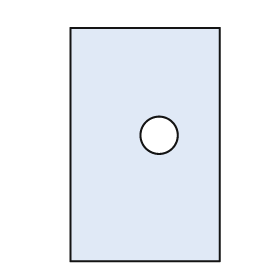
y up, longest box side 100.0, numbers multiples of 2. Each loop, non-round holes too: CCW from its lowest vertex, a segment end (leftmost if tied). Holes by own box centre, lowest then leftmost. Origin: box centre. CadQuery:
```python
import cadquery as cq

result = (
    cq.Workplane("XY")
    .moveTo(-32.0, -50.0)
    .lineTo(32.0, -50.0)
    .lineTo(32.0, 50.0)
    .lineTo(-32.0, 50.0)
    .close()
    .moveTo(6.0, 4.0)
    .circle(8.0)
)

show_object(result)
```